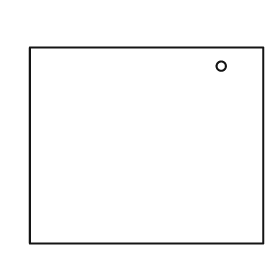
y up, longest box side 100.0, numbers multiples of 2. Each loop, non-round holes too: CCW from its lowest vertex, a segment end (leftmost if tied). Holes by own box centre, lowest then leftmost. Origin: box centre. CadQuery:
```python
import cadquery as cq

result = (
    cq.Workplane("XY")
    .moveTo(-50.0, -42.0)
    .lineTo(50.0, -42.0)
    .lineTo(50.0, 42.0)
    .lineTo(-50.0, 42.0)
    .close()
    .moveTo(32.0, 34.0)
    .circle(2.0)
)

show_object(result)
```